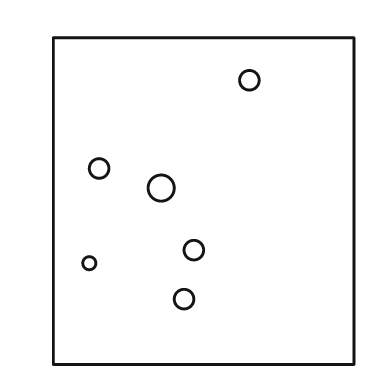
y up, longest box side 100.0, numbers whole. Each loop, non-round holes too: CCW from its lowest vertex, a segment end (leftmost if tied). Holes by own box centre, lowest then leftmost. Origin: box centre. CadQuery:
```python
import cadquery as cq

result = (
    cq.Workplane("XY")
    .moveTo(-46.0, -50.0)
    .lineTo(46.0, -50.0)
    .lineTo(46.0, 50.0)
    .lineTo(-46.0, 50.0)
    .close()
    .moveTo(-6.0, -30.0)
    .circle(3.0)
    .moveTo(-35.0, -19.0)
    .circle(2.0)
    .moveTo(-3.0, -15.0)
    .circle(3.0)
    .moveTo(-13.0, 4.0)
    .circle(4.0)
    .moveTo(-32.0, 10.0)
    .circle(3.0)
    .moveTo(14.0, 37.0)
    .circle(3.0)
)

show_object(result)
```